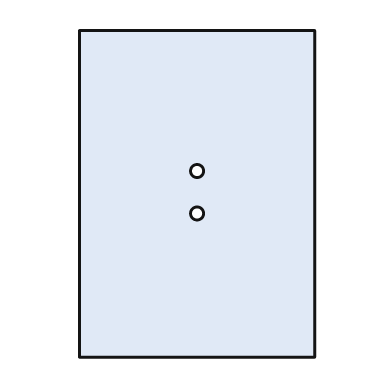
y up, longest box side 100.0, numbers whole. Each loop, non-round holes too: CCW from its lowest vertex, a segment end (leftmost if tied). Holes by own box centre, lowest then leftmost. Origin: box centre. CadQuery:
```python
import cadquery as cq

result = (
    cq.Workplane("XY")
    .moveTo(-36.0, -50.0)
    .lineTo(36.0, -50.0)
    .lineTo(36.0, 50.0)
    .lineTo(-36.0, 50.0)
    .close()
    .moveTo(0.0, -6.0)
    .circle(2.0)
    .moveTo(0.0, 7.0)
    .circle(2.0)
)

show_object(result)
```